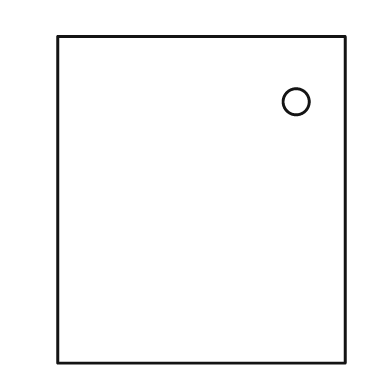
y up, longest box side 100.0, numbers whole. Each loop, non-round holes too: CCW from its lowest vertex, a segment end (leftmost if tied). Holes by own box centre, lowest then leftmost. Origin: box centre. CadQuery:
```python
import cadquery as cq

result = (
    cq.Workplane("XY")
    .moveTo(-44.0, -50.0)
    .lineTo(44.0, -50.0)
    .lineTo(44.0, 50.0)
    .lineTo(-44.0, 50.0)
    .close()
    .moveTo(29.0, 30.0)
    .circle(4.0)
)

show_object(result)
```